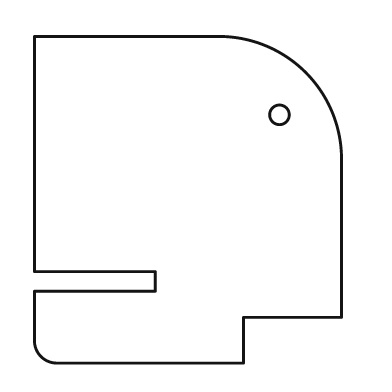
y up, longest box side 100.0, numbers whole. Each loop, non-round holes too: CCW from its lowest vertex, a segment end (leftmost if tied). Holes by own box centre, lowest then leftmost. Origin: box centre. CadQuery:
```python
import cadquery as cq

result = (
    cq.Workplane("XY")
    .moveTo(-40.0, -50.0)
    .lineTo(17.0, -50.0)
    .lineTo(17.0, -36.0)
    .lineTo(47.0, -36.0)
    .lineTo(47.0, 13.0)
    .threePointArc((36.0, 39.0), (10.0, 50.0))
    .lineTo(-47.0, 50.0)
    .lineTo(-47.0, -22.0)
    .lineTo(-10.0, -22.0)
    .lineTo(-10.0, -28.0)
    .lineTo(-47.0, -28.0)
    .lineTo(-47.0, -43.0)
    .threePointArc((-45.0, -48.0), (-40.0, -50.0))
    .close()
    .moveTo(28.0, 26.0)
    .circle(3.0)
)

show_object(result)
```